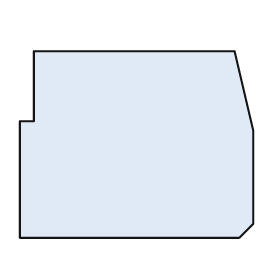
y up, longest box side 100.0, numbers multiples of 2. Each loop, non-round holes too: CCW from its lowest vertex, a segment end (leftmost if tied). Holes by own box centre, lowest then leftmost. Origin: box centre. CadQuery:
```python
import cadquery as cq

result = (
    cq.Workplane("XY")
    .moveTo(-50.0, -40.0)
    .lineTo(44.0, -40.0)
    .lineTo(50.0, -34.0)
    .lineTo(50.0, 6.0)
    .lineTo(42.0, 40.0)
    .lineTo(-44.0, 40.0)
    .lineTo(-44.0, 10.0)
    .lineTo(-50.0, 10.0)
    .close()
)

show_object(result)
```